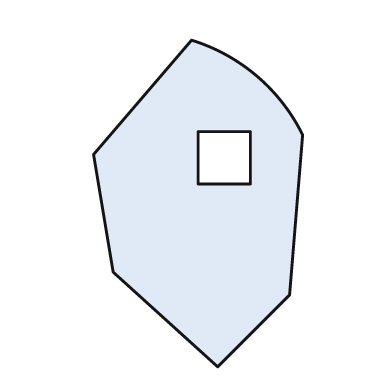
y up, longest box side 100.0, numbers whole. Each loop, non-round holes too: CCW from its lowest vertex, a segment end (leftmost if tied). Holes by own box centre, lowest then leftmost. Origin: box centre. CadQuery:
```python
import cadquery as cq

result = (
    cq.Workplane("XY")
    .moveTo(6.0, -50.0)
    .lineTo(28.0, -28.0)
    .lineTo(32.0, 21.0)
    .threePointArc((18.0, 39.0), (-2.0, 50.0))
    .lineTo(-32.0, 15.0)
    .lineTo(-26.0, -21.0)
    .close()
    .moveTo(0.0, 6.0)
    .lineTo(16.0, 6.0)
    .lineTo(16.0, 22.0)
    .lineTo(0.0, 22.0)
    .close()
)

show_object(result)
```